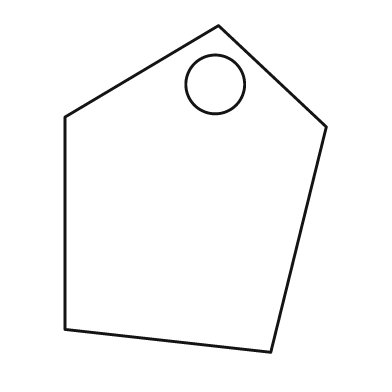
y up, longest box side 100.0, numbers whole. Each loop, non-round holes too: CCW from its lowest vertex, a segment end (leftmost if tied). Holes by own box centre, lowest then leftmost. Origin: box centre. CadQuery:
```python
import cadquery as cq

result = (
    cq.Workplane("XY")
    .moveTo(23.0, -50.0)
    .lineTo(40.0, 19.0)
    .lineTo(7.0, 50.0)
    .lineTo(-40.0, 22.0)
    .lineTo(-40.0, -43.0)
    .close()
    .moveTo(6.0, 32.0)
    .circle(9.0)
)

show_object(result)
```